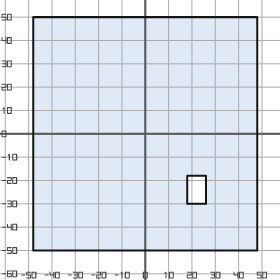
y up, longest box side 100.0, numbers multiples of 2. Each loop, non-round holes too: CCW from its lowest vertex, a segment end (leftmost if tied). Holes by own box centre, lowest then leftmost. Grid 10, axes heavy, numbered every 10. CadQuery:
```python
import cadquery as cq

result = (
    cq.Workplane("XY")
    .moveTo(-48.0, -50.0)
    .lineTo(48.0, -50.0)
    .lineTo(48.0, 50.0)
    .lineTo(-48.0, 50.0)
    .close()
    .moveTo(18.0, -30.0)
    .lineTo(26.0, -30.0)
    .lineTo(26.0, -18.0)
    .lineTo(18.0, -18.0)
    .close()
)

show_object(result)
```